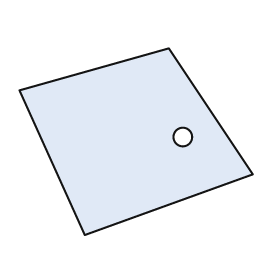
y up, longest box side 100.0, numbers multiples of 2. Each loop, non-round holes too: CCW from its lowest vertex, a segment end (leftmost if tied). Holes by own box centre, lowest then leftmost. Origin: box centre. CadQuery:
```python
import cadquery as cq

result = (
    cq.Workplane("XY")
    .moveTo(-22.0, -40.0)
    .lineTo(50.0, -14.0)
    .lineTo(14.0, 40.0)
    .lineTo(-50.0, 22.0)
    .close()
    .moveTo(20.0, 2.0)
    .circle(4.0)
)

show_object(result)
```